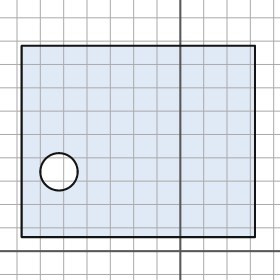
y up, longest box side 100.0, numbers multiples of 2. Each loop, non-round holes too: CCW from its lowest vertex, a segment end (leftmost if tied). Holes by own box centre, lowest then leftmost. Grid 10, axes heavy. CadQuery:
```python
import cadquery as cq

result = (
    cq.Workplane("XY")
    .moveTo(-68.0, 6.0)
    .lineTo(32.0, 6.0)
    .lineTo(32.0, 88.0)
    .lineTo(-68.0, 88.0)
    .close()
    .moveTo(-52.0, 34.0)
    .circle(8.0)
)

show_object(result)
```